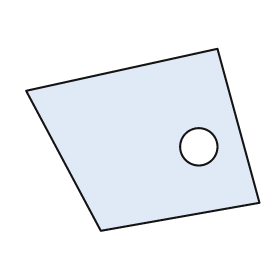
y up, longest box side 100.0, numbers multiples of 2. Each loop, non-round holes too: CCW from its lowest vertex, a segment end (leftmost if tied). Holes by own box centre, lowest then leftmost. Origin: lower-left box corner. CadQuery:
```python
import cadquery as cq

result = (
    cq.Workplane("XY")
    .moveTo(32.0, 0.0)
    .lineTo(100.0, 12.0)
    .lineTo(82.0, 78.0)
    .lineTo(0.0, 60.0)
    .close()
    .moveTo(74.0, 36.0)
    .circle(8.0)
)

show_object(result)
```